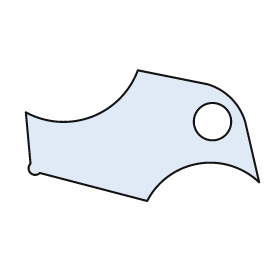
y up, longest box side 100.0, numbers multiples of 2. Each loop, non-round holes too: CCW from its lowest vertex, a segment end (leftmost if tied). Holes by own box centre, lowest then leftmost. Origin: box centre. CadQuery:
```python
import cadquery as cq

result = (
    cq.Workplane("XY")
    .moveTo(2.0, -28.0)
    .threePointArc((24.0, -12.0), (50.0, -20.0))
    .lineTo(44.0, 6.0)
    .threePointArc((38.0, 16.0), (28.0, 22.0))
    .lineTo(-2.0, 28.0)
    .threePointArc((-22.0, 8.0), (-50.0, 10.0))
    .lineTo(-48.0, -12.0)
    .threePointArc((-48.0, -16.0), (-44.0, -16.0))
    .close()
    .moveTo(30.0, 6.0)
    .circle(8.0)
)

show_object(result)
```